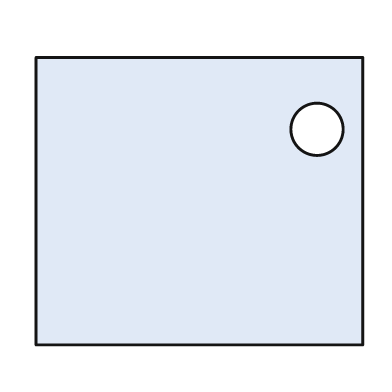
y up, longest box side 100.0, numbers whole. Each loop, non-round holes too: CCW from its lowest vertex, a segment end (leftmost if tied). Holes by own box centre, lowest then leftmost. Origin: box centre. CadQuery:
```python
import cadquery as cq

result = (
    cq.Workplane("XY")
    .moveTo(-50.0, -44.0)
    .lineTo(50.0, -44.0)
    .lineTo(50.0, 44.0)
    .lineTo(-50.0, 44.0)
    .close()
    .moveTo(36.0, 22.0)
    .circle(8.0)
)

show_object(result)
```